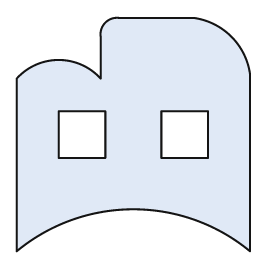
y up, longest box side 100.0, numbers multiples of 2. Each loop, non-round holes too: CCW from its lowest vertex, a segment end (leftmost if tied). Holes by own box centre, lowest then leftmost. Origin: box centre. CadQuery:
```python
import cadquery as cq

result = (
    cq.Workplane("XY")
    .moveTo(-50.0, -50.0)
    .threePointArc((0.0, -32.0), (50.0, -50.0))
    .lineTo(50.0, 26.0)
    .threePointArc((42.0, 42.0), (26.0, 50.0))
    .lineTo(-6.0, 50.0)
    .threePointArc((-12.0, 48.0), (-14.0, 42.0))
    .lineTo(-14.0, 24.0)
    .threePointArc((-32.0, 32.0), (-50.0, 24.0))
    .close()
    .moveTo(-32.0, -10.0)
    .lineTo(-12.0, -10.0)
    .lineTo(-12.0, 10.0)
    .lineTo(-32.0, 10.0)
    .close()
    .moveTo(12.0, -10.0)
    .lineTo(32.0, -10.0)
    .lineTo(32.0, 10.0)
    .lineTo(12.0, 10.0)
    .close()
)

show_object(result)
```